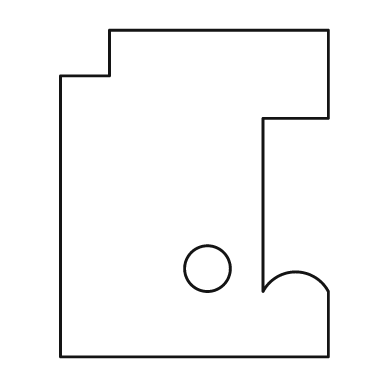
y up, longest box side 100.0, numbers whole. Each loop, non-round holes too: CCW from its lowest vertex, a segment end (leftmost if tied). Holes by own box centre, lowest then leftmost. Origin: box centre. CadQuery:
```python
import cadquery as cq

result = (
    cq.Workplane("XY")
    .moveTo(-41.0, -50.0)
    .lineTo(41.0, -50.0)
    .lineTo(41.0, -30.0)
    .threePointArc((31.0, -24.0), (21.0, -30.0))
    .lineTo(21.0, 23.0)
    .lineTo(41.0, 23.0)
    .lineTo(41.0, 50.0)
    .lineTo(-26.0, 50.0)
    .lineTo(-26.0, 36.0)
    .lineTo(-41.0, 36.0)
    .close()
    .moveTo(4.0, -23.0)
    .circle(7.0)
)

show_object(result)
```